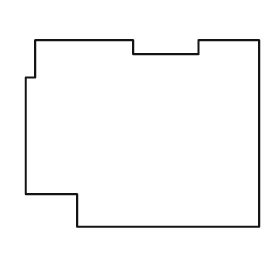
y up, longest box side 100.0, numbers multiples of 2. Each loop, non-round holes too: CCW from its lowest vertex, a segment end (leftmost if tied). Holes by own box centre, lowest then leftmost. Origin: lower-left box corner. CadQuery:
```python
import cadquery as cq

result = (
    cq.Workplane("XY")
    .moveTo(22.0, 0.0)
    .lineTo(100.0, 0.0)
    .lineTo(100.0, 80.0)
    .lineTo(74.0, 80.0)
    .lineTo(74.0, 74.0)
    .lineTo(46.0, 74.0)
    .lineTo(46.0, 80.0)
    .lineTo(4.0, 80.0)
    .lineTo(4.0, 64.0)
    .lineTo(0.0, 64.0)
    .lineTo(0.0, 14.0)
    .lineTo(22.0, 14.0)
    .close()
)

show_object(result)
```